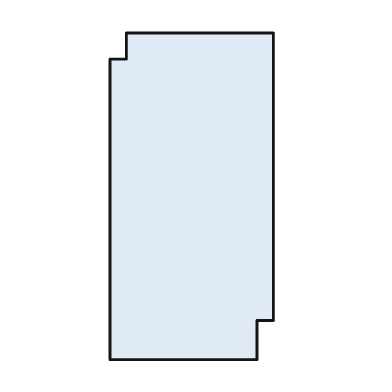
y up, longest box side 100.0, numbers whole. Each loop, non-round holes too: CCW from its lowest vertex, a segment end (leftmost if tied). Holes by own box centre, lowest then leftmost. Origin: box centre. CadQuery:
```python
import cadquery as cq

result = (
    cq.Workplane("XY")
    .moveTo(-25.0, -50.0)
    .lineTo(20.0, -50.0)
    .lineTo(20.0, -38.0)
    .lineTo(25.0, -38.0)
    .lineTo(25.0, 50.0)
    .lineTo(-20.0, 50.0)
    .lineTo(-20.0, 42.0)
    .lineTo(-25.0, 42.0)
    .close()
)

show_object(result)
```